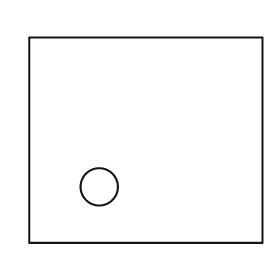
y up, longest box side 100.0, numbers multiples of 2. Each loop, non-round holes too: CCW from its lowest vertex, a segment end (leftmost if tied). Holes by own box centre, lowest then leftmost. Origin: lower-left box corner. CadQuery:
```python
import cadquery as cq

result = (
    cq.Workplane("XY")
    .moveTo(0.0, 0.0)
    .lineTo(100.0, 0.0)
    .lineTo(100.0, 88.0)
    .lineTo(0.0, 88.0)
    .close()
    .moveTo(30.0, 24.0)
    .circle(8.0)
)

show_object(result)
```